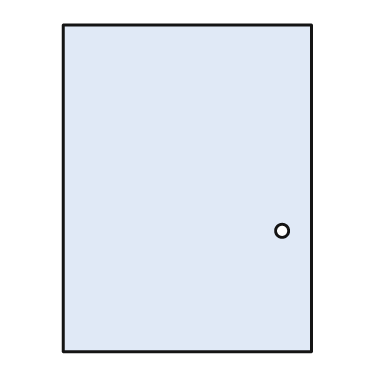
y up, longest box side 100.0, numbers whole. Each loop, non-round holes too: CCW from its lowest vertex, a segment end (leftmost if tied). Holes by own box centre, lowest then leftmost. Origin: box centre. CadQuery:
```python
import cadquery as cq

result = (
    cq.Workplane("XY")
    .moveTo(-38.0, -50.0)
    .lineTo(38.0, -50.0)
    .lineTo(38.0, 50.0)
    .lineTo(-38.0, 50.0)
    .close()
    .moveTo(29.0, -13.0)
    .circle(2.0)
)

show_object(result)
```